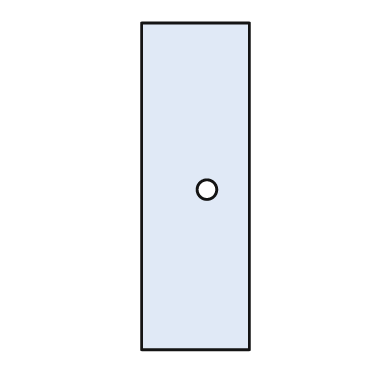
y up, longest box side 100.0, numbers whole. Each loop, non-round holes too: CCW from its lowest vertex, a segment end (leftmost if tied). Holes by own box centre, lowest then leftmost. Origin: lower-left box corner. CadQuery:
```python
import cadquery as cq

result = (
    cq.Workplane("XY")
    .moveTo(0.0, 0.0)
    .lineTo(33.0, 0.0)
    .lineTo(33.0, 100.0)
    .lineTo(0.0, 100.0)
    .close()
    .moveTo(20.0, 49.0)
    .circle(3.0)
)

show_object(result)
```